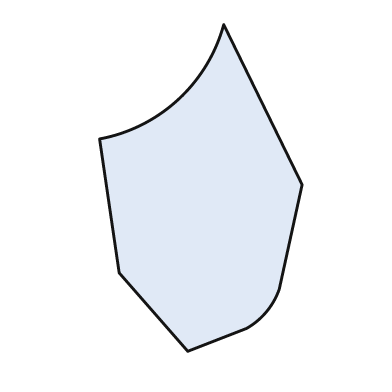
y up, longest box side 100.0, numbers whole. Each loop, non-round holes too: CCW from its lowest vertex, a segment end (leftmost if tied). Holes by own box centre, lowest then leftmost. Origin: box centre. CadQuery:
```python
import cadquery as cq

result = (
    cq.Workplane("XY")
    .moveTo(-4.0, -50.0)
    .lineTo(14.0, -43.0)
    .threePointArc((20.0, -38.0), (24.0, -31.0))
    .lineTo(31.0, 1.0)
    .lineTo(7.0, 50.0)
    .threePointArc((-7.0, 27.0), (-31.0, 15.0))
    .lineTo(-25.0, -26.0)
    .close()
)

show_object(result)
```